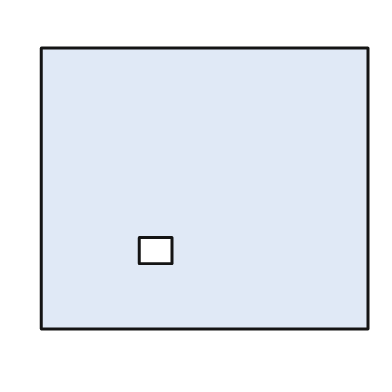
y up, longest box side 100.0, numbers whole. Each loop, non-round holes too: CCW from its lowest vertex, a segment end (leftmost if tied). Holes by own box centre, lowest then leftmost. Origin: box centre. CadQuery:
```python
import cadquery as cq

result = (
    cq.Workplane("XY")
    .moveTo(-50.0, -43.0)
    .lineTo(50.0, -43.0)
    .lineTo(50.0, 43.0)
    .lineTo(-50.0, 43.0)
    .close()
    .moveTo(-20.0, -23.0)
    .lineTo(-10.0, -23.0)
    .lineTo(-10.0, -15.0)
    .lineTo(-20.0, -15.0)
    .close()
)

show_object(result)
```